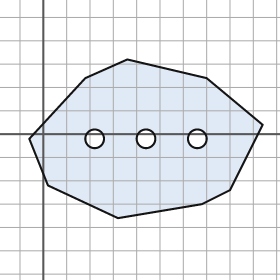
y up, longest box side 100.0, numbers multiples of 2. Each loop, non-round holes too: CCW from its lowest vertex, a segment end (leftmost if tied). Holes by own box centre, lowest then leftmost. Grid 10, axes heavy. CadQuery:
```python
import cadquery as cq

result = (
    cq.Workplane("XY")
    .moveTo(32.0, -36.0)
    .lineTo(68.0, -30.0)
    .lineTo(80.0, -24.0)
    .lineTo(94.0, 4.0)
    .lineTo(70.0, 24.0)
    .lineTo(36.0, 32.0)
    .lineTo(18.0, 24.0)
    .lineTo(-6.0, -2.0)
    .lineTo(2.0, -22.0)
    .close()
    .moveTo(22.0, -2.0)
    .circle(4.0)
    .moveTo(44.0, -2.0)
    .circle(4.0)
    .moveTo(66.0, -2.0)
    .circle(4.0)
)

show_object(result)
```